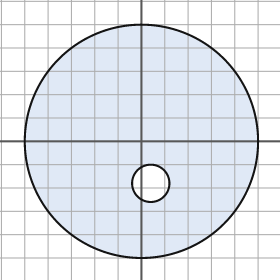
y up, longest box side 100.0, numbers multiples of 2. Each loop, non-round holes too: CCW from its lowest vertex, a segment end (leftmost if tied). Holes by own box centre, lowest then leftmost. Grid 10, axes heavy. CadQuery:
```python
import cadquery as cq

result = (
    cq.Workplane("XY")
    .moveTo(0.0, 0.0)
    .circle(50.0)
    .moveTo(4.0, -18.0)
    .circle(8.0)
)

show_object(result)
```